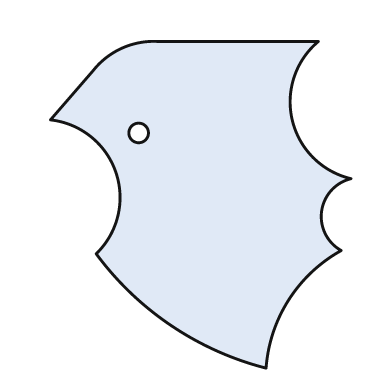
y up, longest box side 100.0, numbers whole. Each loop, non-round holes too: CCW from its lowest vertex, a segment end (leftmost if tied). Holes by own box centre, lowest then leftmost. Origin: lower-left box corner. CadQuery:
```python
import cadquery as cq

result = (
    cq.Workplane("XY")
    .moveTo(66.0, 0.0)
    .threePointArc((73.0, 21.0), (89.0, 36.0))
    .threePointArc((83.0, 48.0), (92.0, 58.0))
    .threePointArc((74.0, 76.0), (82.0, 100.0))
    .lineTo(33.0, 100.0)
    .threePointArc((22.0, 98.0), (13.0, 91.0))
    .lineTo(0.0, 76.0)
    .threePointArc((20.0, 60.0), (14.0, 35.0))
    .threePointArc((37.0, 13.0), (66.0, 0.0))
    .close()
    .moveTo(27.0, 72.0)
    .circle(3.0)
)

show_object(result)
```